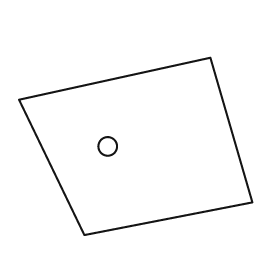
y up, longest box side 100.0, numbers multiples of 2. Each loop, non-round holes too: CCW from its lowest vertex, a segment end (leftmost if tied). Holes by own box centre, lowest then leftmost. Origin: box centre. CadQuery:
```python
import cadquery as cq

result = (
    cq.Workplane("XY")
    .moveTo(-22.0, -38.0)
    .lineTo(50.0, -24.0)
    .lineTo(32.0, 38.0)
    .lineTo(-50.0, 20.0)
    .close()
    .moveTo(-12.0, 0.0)
    .circle(4.0)
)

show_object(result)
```